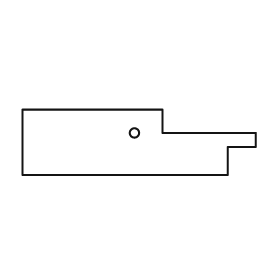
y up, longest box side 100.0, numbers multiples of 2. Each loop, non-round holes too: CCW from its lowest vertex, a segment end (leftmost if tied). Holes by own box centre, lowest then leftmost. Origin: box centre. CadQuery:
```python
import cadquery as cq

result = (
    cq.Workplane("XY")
    .moveTo(-50.0, -14.0)
    .lineTo(38.0, -14.0)
    .lineTo(38.0, -2.0)
    .lineTo(50.0, -2.0)
    .lineTo(50.0, 4.0)
    .lineTo(10.0, 4.0)
    .lineTo(10.0, 14.0)
    .lineTo(-50.0, 14.0)
    .close()
    .moveTo(-2.0, 4.0)
    .circle(2.0)
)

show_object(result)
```